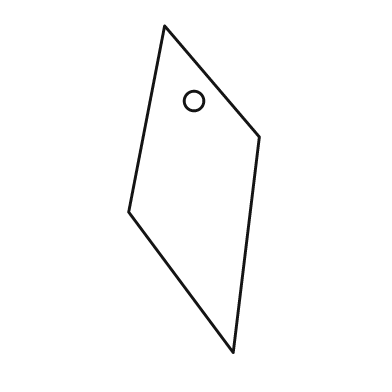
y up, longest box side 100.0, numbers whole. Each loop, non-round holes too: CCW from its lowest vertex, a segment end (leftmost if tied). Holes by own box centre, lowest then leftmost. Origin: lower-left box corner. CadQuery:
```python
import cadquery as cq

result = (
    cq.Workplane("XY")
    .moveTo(32.0, 0.0)
    .lineTo(40.0, 66.0)
    .lineTo(11.0, 100.0)
    .lineTo(0.0, 43.0)
    .close()
    .moveTo(20.0, 77.0)
    .circle(3.0)
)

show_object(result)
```